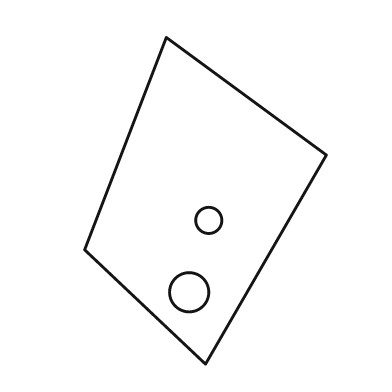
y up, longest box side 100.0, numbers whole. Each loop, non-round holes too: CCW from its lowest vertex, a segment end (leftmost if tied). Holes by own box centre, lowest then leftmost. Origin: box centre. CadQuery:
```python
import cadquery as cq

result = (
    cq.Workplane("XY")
    .moveTo(0.0, -50.0)
    .lineTo(37.0, 14.0)
    .lineTo(-12.0, 50.0)
    .lineTo(-37.0, -15.0)
    .close()
    .moveTo(-5.0, -28.0)
    .circle(6.0)
    .moveTo(1.0, -6.0)
    .circle(4.0)
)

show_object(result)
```